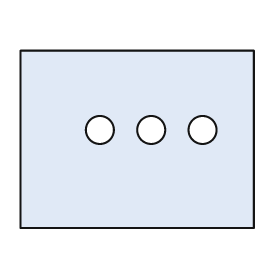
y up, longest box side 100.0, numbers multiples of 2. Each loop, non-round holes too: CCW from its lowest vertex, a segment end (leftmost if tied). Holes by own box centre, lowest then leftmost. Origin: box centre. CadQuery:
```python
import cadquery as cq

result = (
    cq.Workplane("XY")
    .moveTo(-50.0, -38.0)
    .lineTo(50.0, -38.0)
    .lineTo(50.0, 38.0)
    .lineTo(-50.0, 38.0)
    .close()
    .moveTo(-16.0, 4.0)
    .circle(6.0)
    .moveTo(6.0, 4.0)
    .circle(6.0)
    .moveTo(28.0, 4.0)
    .circle(6.0)
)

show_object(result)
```